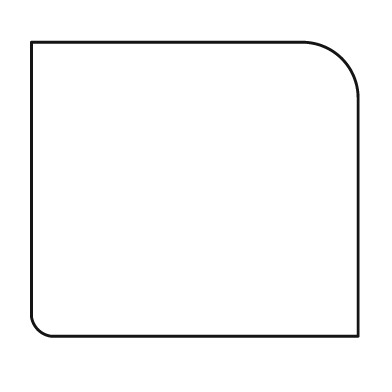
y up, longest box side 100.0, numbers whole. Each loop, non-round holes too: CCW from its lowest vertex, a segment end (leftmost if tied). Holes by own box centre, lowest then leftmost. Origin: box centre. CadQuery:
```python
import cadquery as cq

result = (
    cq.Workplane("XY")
    .moveTo(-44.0, -45.0)
    .lineTo(50.0, -45.0)
    .lineTo(50.0, 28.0)
    .threePointArc((45.0, 40.0), (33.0, 45.0))
    .lineTo(-50.0, 45.0)
    .lineTo(-50.0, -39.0)
    .threePointArc((-48.0, -43.0), (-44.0, -45.0))
    .close()
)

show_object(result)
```